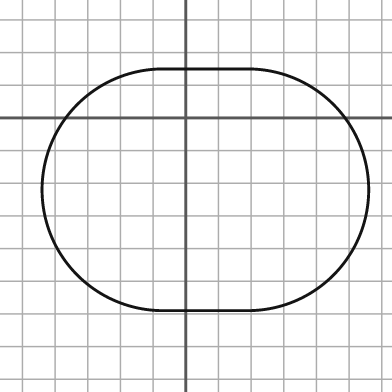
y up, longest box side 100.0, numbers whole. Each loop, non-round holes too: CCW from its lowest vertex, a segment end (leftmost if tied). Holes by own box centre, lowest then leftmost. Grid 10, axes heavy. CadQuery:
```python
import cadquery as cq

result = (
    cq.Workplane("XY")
    .moveTo(-7.0, -59.0)
    .lineTo(19.0, -59.0)
    .threePointArc((56.0, -22.0), (19.0, 15.0))
    .lineTo(-7.0, 15.0)
    .threePointArc((-44.0, -22.0), (-7.0, -59.0))
    .close()
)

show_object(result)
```